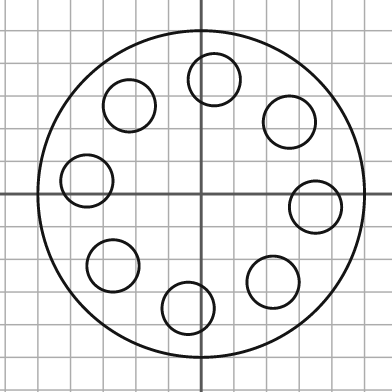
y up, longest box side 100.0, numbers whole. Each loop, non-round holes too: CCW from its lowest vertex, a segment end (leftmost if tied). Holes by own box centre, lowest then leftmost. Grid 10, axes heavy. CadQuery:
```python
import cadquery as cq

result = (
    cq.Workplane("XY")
    .moveTo(0.0, 0.0)
    .circle(50.0)
    .moveTo(-4.0, -35.0)
    .circle(8.0)
    .moveTo(22.0, -27.0)
    .circle(8.0)
    .moveTo(-27.0, -22.0)
    .circle(8.0)
    .moveTo(35.0, -4.0)
    .circle(8.0)
    .moveTo(-35.0, 4.0)
    .circle(8.0)
    .moveTo(27.0, 22.0)
    .circle(8.0)
    .moveTo(-22.0, 27.0)
    .circle(8.0)
    .moveTo(4.0, 35.0)
    .circle(8.0)
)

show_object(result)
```